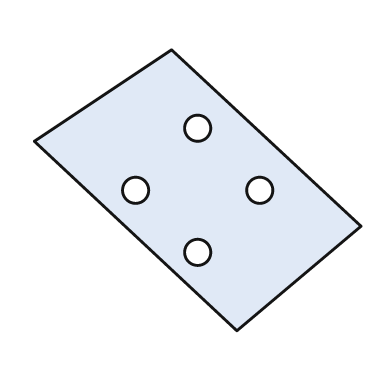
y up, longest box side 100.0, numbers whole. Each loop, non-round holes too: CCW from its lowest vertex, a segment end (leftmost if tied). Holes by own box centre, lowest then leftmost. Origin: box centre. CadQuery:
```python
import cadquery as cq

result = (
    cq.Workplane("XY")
    .moveTo(12.0, -43.0)
    .lineTo(50.0, -11.0)
    .lineTo(-8.0, 43.0)
    .lineTo(-50.0, 15.0)
    .close()
    .moveTo(0.0, -19.0)
    .circle(4.0)
    .moveTo(-19.0, 0.0)
    .circle(4.0)
    .moveTo(19.0, 0.0)
    .circle(4.0)
    .moveTo(0.0, 19.0)
    .circle(4.0)
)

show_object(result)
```